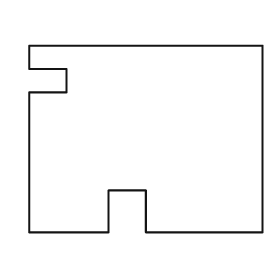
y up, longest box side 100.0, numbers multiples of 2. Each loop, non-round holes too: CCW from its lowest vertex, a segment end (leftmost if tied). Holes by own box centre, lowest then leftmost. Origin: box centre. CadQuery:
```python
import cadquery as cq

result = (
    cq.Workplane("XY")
    .moveTo(-50.0, -40.0)
    .lineTo(-16.0, -40.0)
    .lineTo(-16.0, -22.0)
    .lineTo(0.0, -22.0)
    .lineTo(0.0, -40.0)
    .lineTo(50.0, -40.0)
    .lineTo(50.0, 40.0)
    .lineTo(-50.0, 40.0)
    .lineTo(-50.0, 30.0)
    .lineTo(-34.0, 30.0)
    .lineTo(-34.0, 20.0)
    .lineTo(-50.0, 20.0)
    .close()
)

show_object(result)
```